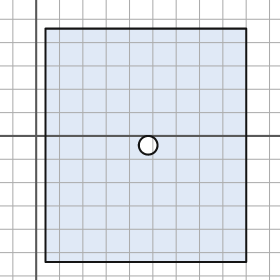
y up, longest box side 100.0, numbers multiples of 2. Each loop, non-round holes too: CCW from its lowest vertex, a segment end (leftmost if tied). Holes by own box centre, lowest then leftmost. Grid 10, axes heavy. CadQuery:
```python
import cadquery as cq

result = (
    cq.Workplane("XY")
    .moveTo(4.0, -54.0)
    .lineTo(90.0, -54.0)
    .lineTo(90.0, 46.0)
    .lineTo(4.0, 46.0)
    .close()
    .moveTo(48.0, -4.0)
    .circle(4.0)
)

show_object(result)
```